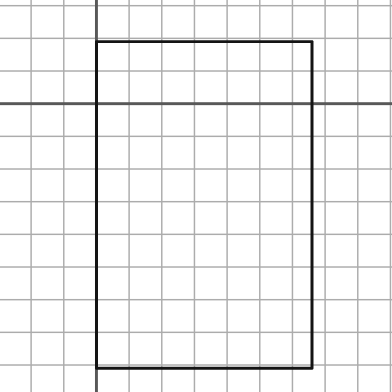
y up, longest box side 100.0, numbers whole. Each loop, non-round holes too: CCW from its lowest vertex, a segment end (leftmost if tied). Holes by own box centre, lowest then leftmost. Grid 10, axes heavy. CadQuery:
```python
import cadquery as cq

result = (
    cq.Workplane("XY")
    .moveTo(0.0, -81.0)
    .lineTo(66.0, -81.0)
    .lineTo(66.0, 19.0)
    .lineTo(0.0, 19.0)
    .close()
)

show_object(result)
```